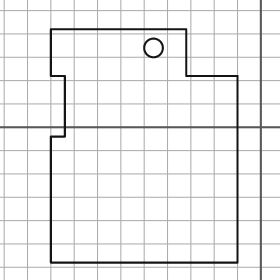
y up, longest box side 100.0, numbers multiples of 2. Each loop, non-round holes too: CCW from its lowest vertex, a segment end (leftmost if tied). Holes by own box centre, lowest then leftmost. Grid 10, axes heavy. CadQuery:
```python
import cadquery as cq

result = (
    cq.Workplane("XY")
    .moveTo(-90.0, -58.0)
    .lineTo(-10.0, -58.0)
    .lineTo(-10.0, 22.0)
    .lineTo(-32.0, 22.0)
    .lineTo(-32.0, 42.0)
    .lineTo(-90.0, 42.0)
    .lineTo(-90.0, 22.0)
    .lineTo(-84.0, 22.0)
    .lineTo(-84.0, -4.0)
    .lineTo(-90.0, -4.0)
    .close()
    .moveTo(-46.0, 34.0)
    .circle(4.0)
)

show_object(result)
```